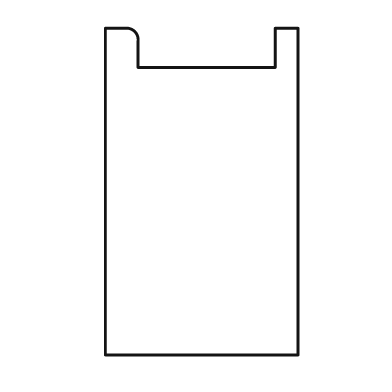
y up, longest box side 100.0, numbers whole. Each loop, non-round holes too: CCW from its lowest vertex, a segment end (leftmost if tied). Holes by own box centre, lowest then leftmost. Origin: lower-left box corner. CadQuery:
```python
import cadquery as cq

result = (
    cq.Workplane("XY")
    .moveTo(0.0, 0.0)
    .lineTo(59.0, 0.0)
    .lineTo(59.0, 100.0)
    .lineTo(52.0, 100.0)
    .lineTo(52.0, 88.0)
    .lineTo(10.0, 88.0)
    .lineTo(10.0, 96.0)
    .threePointArc((9.0, 99.0), (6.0, 100.0))
    .lineTo(0.0, 100.0)
    .close()
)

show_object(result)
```